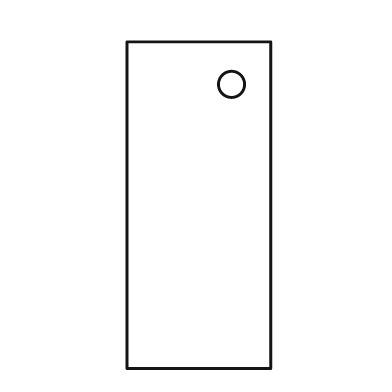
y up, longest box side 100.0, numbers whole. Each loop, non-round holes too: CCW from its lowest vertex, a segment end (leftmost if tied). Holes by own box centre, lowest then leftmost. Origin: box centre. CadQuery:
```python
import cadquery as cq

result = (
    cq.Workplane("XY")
    .moveTo(-22.0, -50.0)
    .lineTo(22.0, -50.0)
    .lineTo(22.0, 50.0)
    .lineTo(-22.0, 50.0)
    .close()
    .moveTo(10.0, 37.0)
    .circle(4.0)
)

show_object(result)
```